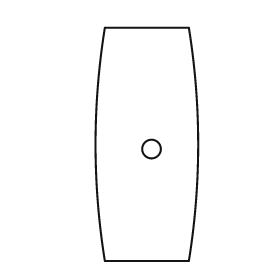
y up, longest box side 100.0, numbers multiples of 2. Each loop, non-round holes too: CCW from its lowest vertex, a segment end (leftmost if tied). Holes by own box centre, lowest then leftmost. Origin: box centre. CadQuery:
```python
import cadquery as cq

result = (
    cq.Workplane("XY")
    .moveTo(-18.0, -50.0)
    .lineTo(18.0, -50.0)
    .threePointArc((22.0, 0.0), (18.0, 50.0))
    .lineTo(-18.0, 50.0)
    .threePointArc((-22.0, 0.0), (-18.0, -50.0))
    .close()
    .moveTo(2.0, -2.0)
    .circle(4.0)
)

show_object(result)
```